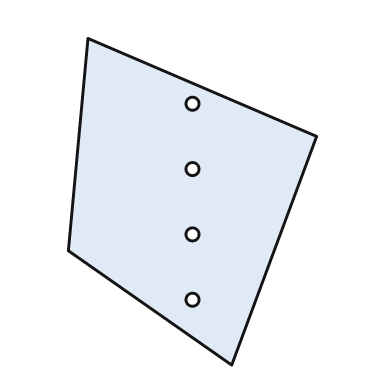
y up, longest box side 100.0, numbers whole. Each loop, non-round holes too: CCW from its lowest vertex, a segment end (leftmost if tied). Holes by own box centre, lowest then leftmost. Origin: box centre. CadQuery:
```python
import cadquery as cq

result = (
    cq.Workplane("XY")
    .moveTo(12.0, -50.0)
    .lineTo(38.0, 20.0)
    .lineTo(-32.0, 50.0)
    .lineTo(-38.0, -15.0)
    .close()
    .moveTo(0.0, -30.0)
    .circle(2.0)
    .moveTo(0.0, -10.0)
    .circle(2.0)
    .moveTo(0.0, 10.0)
    .circle(2.0)
    .moveTo(0.0, 30.0)
    .circle(2.0)
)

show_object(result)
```